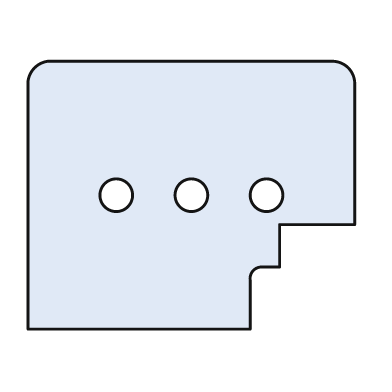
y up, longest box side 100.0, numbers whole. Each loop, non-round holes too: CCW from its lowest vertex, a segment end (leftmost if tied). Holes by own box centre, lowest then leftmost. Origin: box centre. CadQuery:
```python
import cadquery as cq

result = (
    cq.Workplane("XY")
    .moveTo(-50.0, -41.0)
    .lineTo(18.0, -41.0)
    .lineTo(18.0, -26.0)
    .threePointArc((19.0, -23.0), (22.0, -22.0))
    .lineTo(27.0, -22.0)
    .lineTo(27.0, -9.0)
    .lineTo(50.0, -9.0)
    .lineTo(50.0, 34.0)
    .threePointArc((48.0, 39.0), (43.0, 41.0))
    .lineTo(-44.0, 41.0)
    .threePointArc((-48.0, 39.0), (-50.0, 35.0))
    .close()
    .moveTo(-23.0, 0.0)
    .circle(5.0)
    .moveTo(0.0, 0.0)
    .circle(5.0)
    .moveTo(23.0, 0.0)
    .circle(5.0)
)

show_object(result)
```